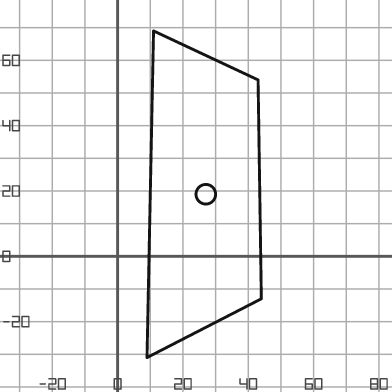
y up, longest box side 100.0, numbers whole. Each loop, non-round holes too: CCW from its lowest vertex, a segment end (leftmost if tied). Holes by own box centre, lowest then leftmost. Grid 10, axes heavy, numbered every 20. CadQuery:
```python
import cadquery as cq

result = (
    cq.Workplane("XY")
    .moveTo(9.0, -31.0)
    .lineTo(44.0, -13.0)
    .lineTo(43.0, 54.0)
    .lineTo(11.0, 69.0)
    .close()
    .moveTo(27.0, 19.0)
    .circle(3.0)
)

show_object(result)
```